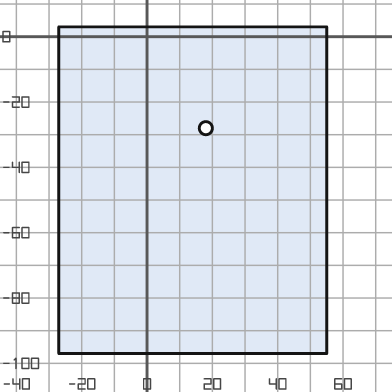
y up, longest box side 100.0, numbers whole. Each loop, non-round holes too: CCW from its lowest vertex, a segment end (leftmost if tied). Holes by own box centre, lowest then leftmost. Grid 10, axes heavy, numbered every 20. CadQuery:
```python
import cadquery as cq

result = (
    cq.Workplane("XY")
    .moveTo(-27.0, -97.0)
    .lineTo(55.0, -97.0)
    .lineTo(55.0, 3.0)
    .lineTo(-27.0, 3.0)
    .close()
    .moveTo(18.0, -28.0)
    .circle(2.0)
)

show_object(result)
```